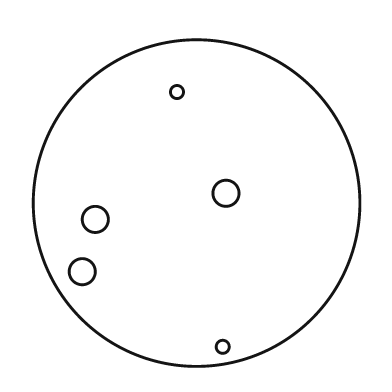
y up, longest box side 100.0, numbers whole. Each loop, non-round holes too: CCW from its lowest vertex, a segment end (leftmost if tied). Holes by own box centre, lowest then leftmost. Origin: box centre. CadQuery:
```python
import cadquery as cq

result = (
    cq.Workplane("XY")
    .moveTo(0.0, 0.0)
    .circle(50.0)
    .moveTo(8.0, -44.0)
    .circle(2.0)
    .moveTo(-35.0, -21.0)
    .circle(4.0)
    .moveTo(-31.0, -5.0)
    .circle(4.0)
    .moveTo(9.0, 3.0)
    .circle(4.0)
    .moveTo(-6.0, 34.0)
    .circle(2.0)
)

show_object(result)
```